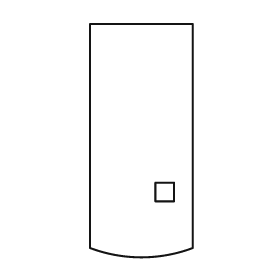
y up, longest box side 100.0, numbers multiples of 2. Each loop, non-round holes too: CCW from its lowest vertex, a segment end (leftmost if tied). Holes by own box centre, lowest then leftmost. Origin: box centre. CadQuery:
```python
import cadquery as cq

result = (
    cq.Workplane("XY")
    .moveTo(-22.0, -46.0)
    .threePointArc((0.0, -50.0), (22.0, -46.0))
    .lineTo(22.0, 50.0)
    .lineTo(-22.0, 50.0)
    .close()
    .moveTo(6.0, -26.0)
    .lineTo(14.0, -26.0)
    .lineTo(14.0, -18.0)
    .lineTo(6.0, -18.0)
    .close()
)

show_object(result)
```